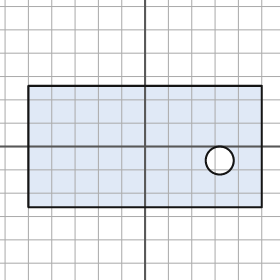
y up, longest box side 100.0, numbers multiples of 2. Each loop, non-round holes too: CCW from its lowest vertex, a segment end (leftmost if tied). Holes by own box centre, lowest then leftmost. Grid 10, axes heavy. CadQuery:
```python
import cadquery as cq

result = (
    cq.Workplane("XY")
    .moveTo(-50.0, -26.0)
    .lineTo(50.0, -26.0)
    .lineTo(50.0, 26.0)
    .lineTo(-50.0, 26.0)
    .close()
    .moveTo(32.0, -6.0)
    .circle(6.0)
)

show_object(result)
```